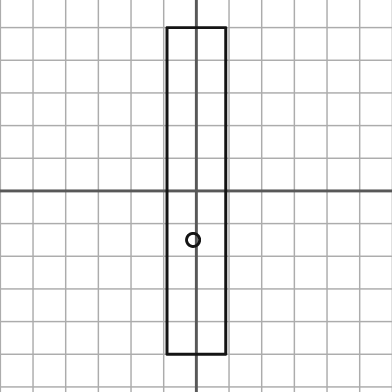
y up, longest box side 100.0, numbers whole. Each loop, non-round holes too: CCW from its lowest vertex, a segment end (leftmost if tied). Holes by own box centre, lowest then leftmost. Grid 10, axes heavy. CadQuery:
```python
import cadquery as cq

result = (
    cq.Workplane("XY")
    .moveTo(-9.0, -50.0)
    .lineTo(9.0, -50.0)
    .lineTo(9.0, 50.0)
    .lineTo(-9.0, 50.0)
    .close()
    .moveTo(-1.0, -15.0)
    .circle(2.0)
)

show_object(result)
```